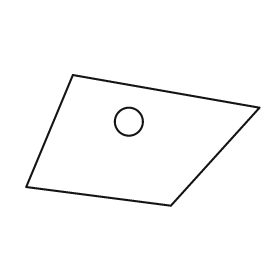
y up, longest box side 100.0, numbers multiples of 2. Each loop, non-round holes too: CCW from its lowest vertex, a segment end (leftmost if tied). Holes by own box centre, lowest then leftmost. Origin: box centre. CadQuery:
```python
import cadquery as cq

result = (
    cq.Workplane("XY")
    .moveTo(12.0, -28.0)
    .lineTo(50.0, 14.0)
    .lineTo(-30.0, 28.0)
    .lineTo(-50.0, -20.0)
    .close()
    .moveTo(-6.0, 8.0)
    .circle(6.0)
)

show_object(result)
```